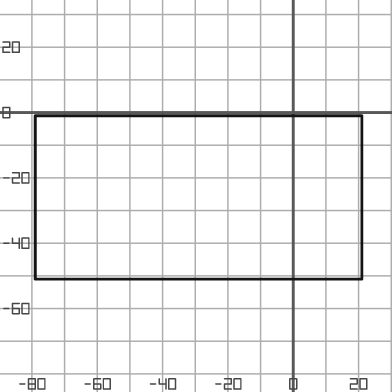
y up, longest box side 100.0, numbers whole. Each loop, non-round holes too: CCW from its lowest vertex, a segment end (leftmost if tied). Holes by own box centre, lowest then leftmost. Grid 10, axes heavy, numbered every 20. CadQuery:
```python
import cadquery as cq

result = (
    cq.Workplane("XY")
    .moveTo(-79.0, -51.0)
    .lineTo(21.0, -51.0)
    .lineTo(21.0, -1.0)
    .lineTo(-79.0, -1.0)
    .close()
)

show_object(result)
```